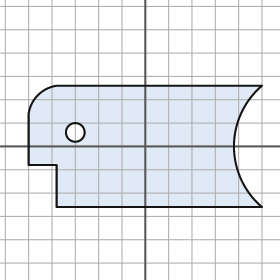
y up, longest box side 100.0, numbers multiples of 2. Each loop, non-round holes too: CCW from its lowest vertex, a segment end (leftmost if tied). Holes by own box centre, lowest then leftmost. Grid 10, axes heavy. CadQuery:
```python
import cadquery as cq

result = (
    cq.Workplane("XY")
    .moveTo(-38.0, -26.0)
    .lineTo(50.0, -26.0)
    .threePointArc((38.0, 0.0), (50.0, 26.0))
    .lineTo(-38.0, 26.0)
    .threePointArc((-46.0, 22.0), (-50.0, 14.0))
    .lineTo(-50.0, -8.0)
    .lineTo(-38.0, -8.0)
    .close()
    .moveTo(-30.0, 6.0)
    .circle(4.0)
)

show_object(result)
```